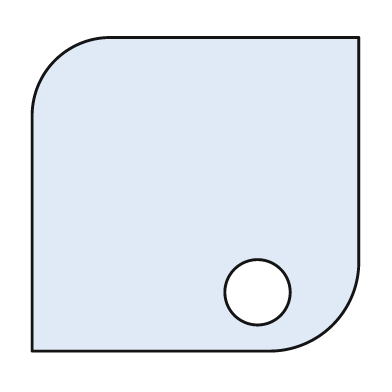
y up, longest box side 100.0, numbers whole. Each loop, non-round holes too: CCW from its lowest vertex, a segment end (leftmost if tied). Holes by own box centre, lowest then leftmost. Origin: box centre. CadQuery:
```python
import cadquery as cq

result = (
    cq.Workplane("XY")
    .moveTo(-50.0, -48.0)
    .lineTo(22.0, -48.0)
    .threePointArc((42.0, -40.0), (50.0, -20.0))
    .lineTo(50.0, 48.0)
    .lineTo(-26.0, 48.0)
    .threePointArc((-43.0, 41.0), (-50.0, 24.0))
    .close()
    .moveTo(19.0, -30.0)
    .circle(10.0)
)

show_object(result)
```